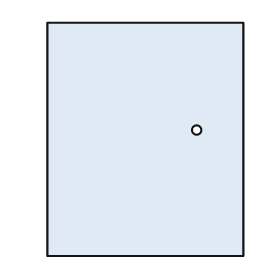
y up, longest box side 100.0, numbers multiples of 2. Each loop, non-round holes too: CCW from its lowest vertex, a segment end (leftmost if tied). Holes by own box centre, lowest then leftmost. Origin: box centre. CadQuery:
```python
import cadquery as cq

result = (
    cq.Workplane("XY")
    .moveTo(-42.0, -50.0)
    .lineTo(42.0, -50.0)
    .lineTo(42.0, 50.0)
    .lineTo(-42.0, 50.0)
    .close()
    .moveTo(22.0, 4.0)
    .circle(2.0)
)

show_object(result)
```